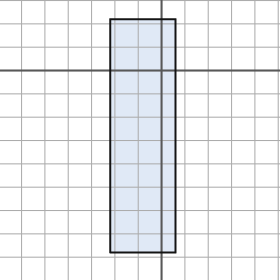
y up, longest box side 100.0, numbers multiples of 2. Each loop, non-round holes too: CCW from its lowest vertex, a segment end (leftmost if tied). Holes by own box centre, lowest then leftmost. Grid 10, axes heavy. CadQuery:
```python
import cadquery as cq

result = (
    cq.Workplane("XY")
    .moveTo(-22.0, -78.0)
    .lineTo(6.0, -78.0)
    .lineTo(6.0, 22.0)
    .lineTo(-22.0, 22.0)
    .close()
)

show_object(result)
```